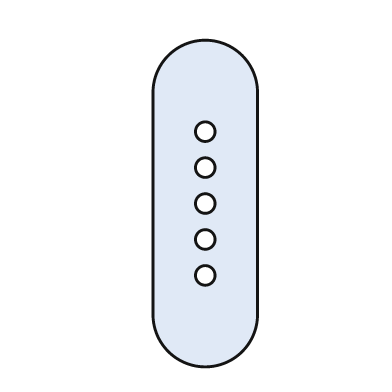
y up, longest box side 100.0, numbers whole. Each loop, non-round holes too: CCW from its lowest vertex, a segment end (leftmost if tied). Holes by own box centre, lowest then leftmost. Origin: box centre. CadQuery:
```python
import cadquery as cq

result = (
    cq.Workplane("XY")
    .moveTo(-16.0, -34.0)
    .threePointArc((0.0, -50.0), (16.0, -34.0))
    .lineTo(16.0, 34.0)
    .threePointArc((0.0, 50.0), (-16.0, 34.0))
    .close()
    .moveTo(0.0, -22.0)
    .circle(3.0)
    .moveTo(0.0, -11.0)
    .circle(3.0)
    .moveTo(0.0, 0.0)
    .circle(3.0)
    .moveTo(0.0, 11.0)
    .circle(3.0)
    .moveTo(0.0, 22.0)
    .circle(3.0)
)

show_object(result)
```